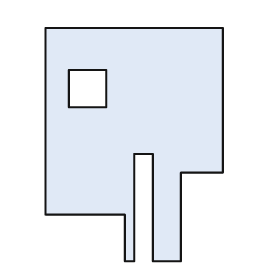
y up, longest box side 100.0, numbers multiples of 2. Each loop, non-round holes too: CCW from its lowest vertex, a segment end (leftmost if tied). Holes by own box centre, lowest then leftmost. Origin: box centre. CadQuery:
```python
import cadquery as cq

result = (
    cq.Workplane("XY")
    .moveTo(-4.0, -50.0)
    .lineTo(0.0, -50.0)
    .lineTo(0.0, -4.0)
    .lineTo(8.0, -4.0)
    .lineTo(8.0, -50.0)
    .lineTo(20.0, -50.0)
    .lineTo(20.0, -12.0)
    .lineTo(38.0, -12.0)
    .lineTo(38.0, 50.0)
    .lineTo(-38.0, 50.0)
    .lineTo(-38.0, -30.0)
    .lineTo(-4.0, -30.0)
    .close()
    .moveTo(-28.0, 16.0)
    .lineTo(-12.0, 16.0)
    .lineTo(-12.0, 32.0)
    .lineTo(-28.0, 32.0)
    .close()
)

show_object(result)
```